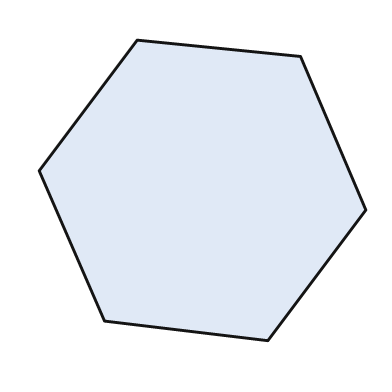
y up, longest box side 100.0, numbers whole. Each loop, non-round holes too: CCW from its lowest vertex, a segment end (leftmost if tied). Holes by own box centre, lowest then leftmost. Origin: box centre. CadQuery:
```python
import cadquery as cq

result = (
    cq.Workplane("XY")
    .moveTo(20.0, -46.0)
    .lineTo(50.0, -6.0)
    .lineTo(30.0, 41.0)
    .lineTo(-20.0, 46.0)
    .lineTo(-50.0, 6.0)
    .lineTo(-30.0, -40.0)
    .close()
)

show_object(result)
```